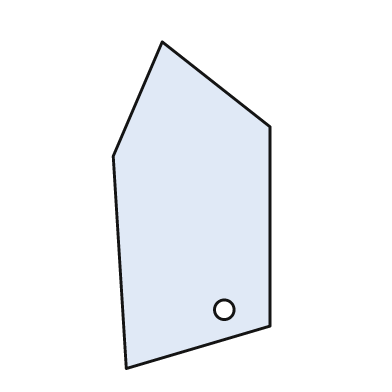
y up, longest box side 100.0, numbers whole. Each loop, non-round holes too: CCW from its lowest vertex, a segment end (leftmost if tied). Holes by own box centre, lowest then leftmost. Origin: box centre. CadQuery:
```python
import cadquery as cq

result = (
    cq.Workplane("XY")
    .moveTo(-20.0, -50.0)
    .lineTo(24.0, -37.0)
    .lineTo(24.0, 24.0)
    .lineTo(-9.0, 50.0)
    .lineTo(-24.0, 15.0)
    .close()
    .moveTo(10.0, -32.0)
    .circle(3.0)
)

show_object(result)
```